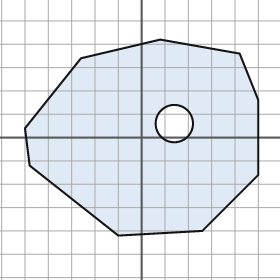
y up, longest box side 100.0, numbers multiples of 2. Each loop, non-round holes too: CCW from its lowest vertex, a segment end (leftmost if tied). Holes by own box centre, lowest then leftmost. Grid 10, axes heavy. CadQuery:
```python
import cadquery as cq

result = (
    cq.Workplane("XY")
    .moveTo(-10.0, -42.0)
    .lineTo(26.0, -40.0)
    .lineTo(50.0, -16.0)
    .lineTo(50.0, 16.0)
    .lineTo(42.0, 36.0)
    .lineTo(8.0, 42.0)
    .lineTo(-26.0, 34.0)
    .lineTo(-50.0, 4.0)
    .lineTo(-48.0, -12.0)
    .close()
    .moveTo(14.0, 6.0)
    .circle(8.0)
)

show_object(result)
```